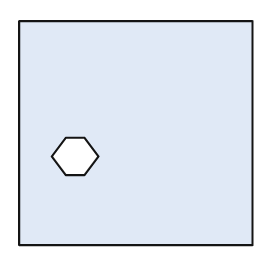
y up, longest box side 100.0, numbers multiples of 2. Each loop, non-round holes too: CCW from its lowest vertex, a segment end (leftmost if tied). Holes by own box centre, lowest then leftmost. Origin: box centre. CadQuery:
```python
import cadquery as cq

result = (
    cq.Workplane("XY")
    .moveTo(-50.0, -48.0)
    .lineTo(50.0, -48.0)
    .lineTo(50.0, 48.0)
    .lineTo(-50.0, 48.0)
    .close()
    .moveTo(-30.0, -18.0)
    .lineTo(-22.0, -18.0)
    .lineTo(-16.0, -10.0)
    .lineTo(-22.0, -2.0)
    .lineTo(-30.0, -2.0)
    .lineTo(-36.0, -10.0)
    .close()
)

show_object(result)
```